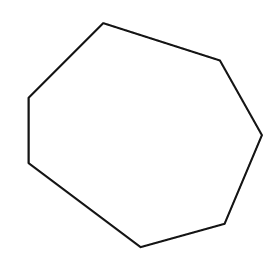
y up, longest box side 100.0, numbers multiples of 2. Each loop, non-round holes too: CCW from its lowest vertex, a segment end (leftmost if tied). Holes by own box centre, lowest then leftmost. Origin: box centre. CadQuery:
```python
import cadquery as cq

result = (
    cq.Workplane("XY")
    .moveTo(-2.0, -48.0)
    .lineTo(34.0, -38.0)
    .lineTo(50.0, 0.0)
    .lineTo(32.0, 32.0)
    .lineTo(-18.0, 48.0)
    .lineTo(-50.0, 16.0)
    .lineTo(-50.0, -12.0)
    .close()
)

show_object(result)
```